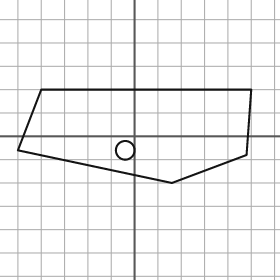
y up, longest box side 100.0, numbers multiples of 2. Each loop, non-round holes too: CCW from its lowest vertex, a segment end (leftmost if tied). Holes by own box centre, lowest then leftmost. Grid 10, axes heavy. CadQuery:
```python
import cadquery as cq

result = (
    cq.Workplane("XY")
    .moveTo(16.0, -20.0)
    .lineTo(48.0, -8.0)
    .lineTo(50.0, 20.0)
    .lineTo(-40.0, 20.0)
    .lineTo(-50.0, -6.0)
    .close()
    .moveTo(-4.0, -6.0)
    .circle(4.0)
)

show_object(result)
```